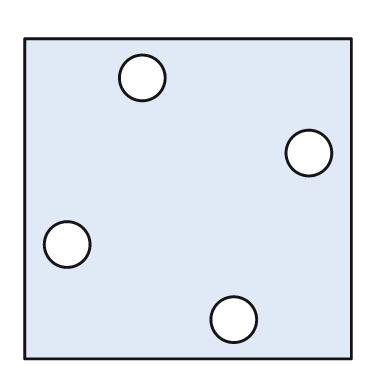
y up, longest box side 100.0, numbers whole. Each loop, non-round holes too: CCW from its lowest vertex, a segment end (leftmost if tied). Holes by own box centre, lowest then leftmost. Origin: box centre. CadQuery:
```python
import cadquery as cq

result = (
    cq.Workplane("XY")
    .moveTo(-50.0, -49.0)
    .lineTo(50.0, -49.0)
    .lineTo(50.0, 49.0)
    .lineTo(-50.0, 49.0)
    .close()
    .moveTo(14.0, -37.0)
    .circle(7.0)
    .moveTo(-37.0, -14.0)
    .circle(7.0)
    .moveTo(37.0, 14.0)
    .circle(7.0)
    .moveTo(-14.0, 37.0)
    .circle(7.0)
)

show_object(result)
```